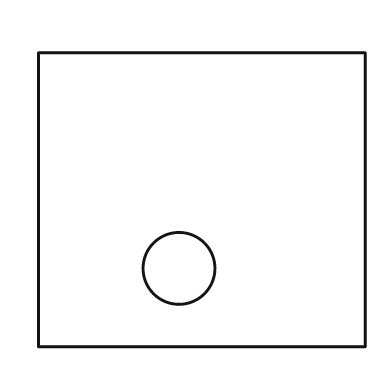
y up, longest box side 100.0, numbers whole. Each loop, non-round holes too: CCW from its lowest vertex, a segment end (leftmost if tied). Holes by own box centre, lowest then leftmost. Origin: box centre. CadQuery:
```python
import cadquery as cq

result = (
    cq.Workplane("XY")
    .moveTo(-50.0, -45.0)
    .lineTo(50.0, -45.0)
    .lineTo(50.0, 45.0)
    .lineTo(-50.0, 45.0)
    .close()
    .moveTo(-7.0, -21.0)
    .circle(11.0)
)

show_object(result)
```